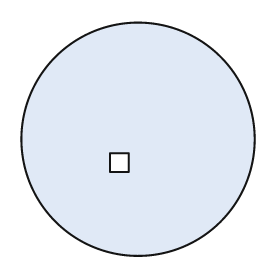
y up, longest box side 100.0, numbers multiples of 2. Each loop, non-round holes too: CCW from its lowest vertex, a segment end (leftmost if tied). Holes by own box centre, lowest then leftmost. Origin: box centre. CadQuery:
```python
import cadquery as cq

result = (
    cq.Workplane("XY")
    .moveTo(0.0, 0.0)
    .circle(50.0)
    .moveTo(-12.0, -14.0)
    .lineTo(-4.0, -14.0)
    .lineTo(-4.0, -6.0)
    .lineTo(-12.0, -6.0)
    .close()
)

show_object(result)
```